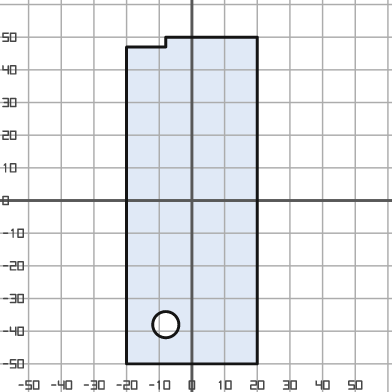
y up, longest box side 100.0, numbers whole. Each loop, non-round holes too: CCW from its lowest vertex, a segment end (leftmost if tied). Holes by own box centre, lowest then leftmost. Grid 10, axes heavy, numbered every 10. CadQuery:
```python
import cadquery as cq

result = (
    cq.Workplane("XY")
    .moveTo(-20.0, -50.0)
    .lineTo(20.0, -50.0)
    .lineTo(20.0, 50.0)
    .lineTo(-8.0, 50.0)
    .lineTo(-8.0, 47.0)
    .lineTo(-20.0, 47.0)
    .close()
    .moveTo(-8.0, -38.0)
    .circle(4.0)
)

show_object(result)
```